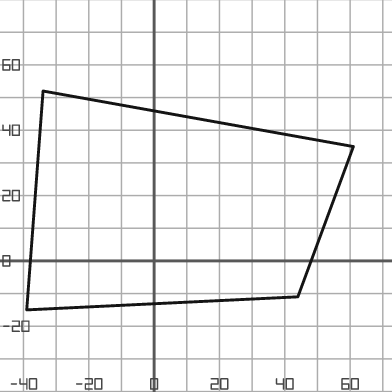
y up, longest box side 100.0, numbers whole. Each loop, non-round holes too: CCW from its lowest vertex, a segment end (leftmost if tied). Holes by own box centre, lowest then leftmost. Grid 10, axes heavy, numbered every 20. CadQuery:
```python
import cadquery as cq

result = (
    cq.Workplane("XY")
    .moveTo(-39.0, -15.0)
    .lineTo(44.0, -11.0)
    .lineTo(61.0, 35.0)
    .lineTo(-34.0, 52.0)
    .close()
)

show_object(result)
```